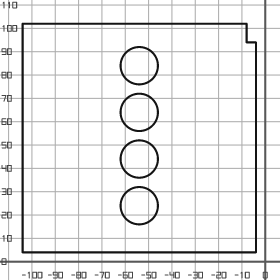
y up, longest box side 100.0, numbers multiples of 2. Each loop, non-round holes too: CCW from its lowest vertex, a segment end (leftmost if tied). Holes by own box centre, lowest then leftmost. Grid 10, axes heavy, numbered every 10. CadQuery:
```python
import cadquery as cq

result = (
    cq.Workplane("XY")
    .moveTo(-104.0, 4.0)
    .lineTo(-4.0, 4.0)
    .lineTo(-4.0, 94.0)
    .lineTo(-8.0, 94.0)
    .lineTo(-8.0, 102.0)
    .lineTo(-104.0, 102.0)
    .close()
    .moveTo(-54.0, 24.0)
    .circle(8.0)
    .moveTo(-54.0, 44.0)
    .circle(8.0)
    .moveTo(-54.0, 64.0)
    .circle(8.0)
    .moveTo(-54.0, 84.0)
    .circle(8.0)
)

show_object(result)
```